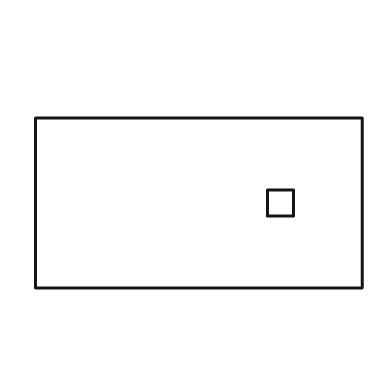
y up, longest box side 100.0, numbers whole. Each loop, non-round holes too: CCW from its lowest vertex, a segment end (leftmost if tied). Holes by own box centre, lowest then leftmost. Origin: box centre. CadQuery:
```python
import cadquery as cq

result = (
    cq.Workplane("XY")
    .moveTo(-50.0, -26.0)
    .lineTo(50.0, -26.0)
    .lineTo(50.0, 26.0)
    .lineTo(-50.0, 26.0)
    .close()
    .moveTo(21.0, -4.0)
    .lineTo(29.0, -4.0)
    .lineTo(29.0, 4.0)
    .lineTo(21.0, 4.0)
    .close()
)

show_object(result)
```